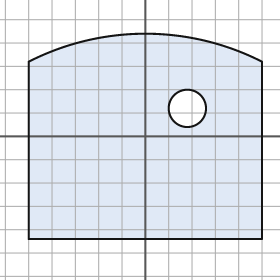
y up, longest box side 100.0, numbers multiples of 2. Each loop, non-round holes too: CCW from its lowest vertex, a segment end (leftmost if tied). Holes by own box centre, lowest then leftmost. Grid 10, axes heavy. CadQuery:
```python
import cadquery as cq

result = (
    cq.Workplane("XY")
    .moveTo(-50.0, -44.0)
    .lineTo(50.0, -44.0)
    .lineTo(50.0, 32.0)
    .threePointArc((0.0, 44.0), (-50.0, 32.0))
    .close()
    .moveTo(18.0, 12.0)
    .circle(8.0)
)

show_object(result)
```